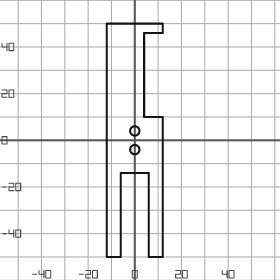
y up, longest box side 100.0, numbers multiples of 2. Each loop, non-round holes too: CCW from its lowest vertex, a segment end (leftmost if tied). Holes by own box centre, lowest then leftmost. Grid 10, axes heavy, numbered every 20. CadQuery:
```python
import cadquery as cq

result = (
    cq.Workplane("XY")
    .moveTo(-12.0, -50.0)
    .lineTo(-6.0, -50.0)
    .lineTo(-6.0, -14.0)
    .lineTo(6.0, -14.0)
    .lineTo(6.0, -50.0)
    .lineTo(12.0, -50.0)
    .lineTo(12.0, 10.0)
    .lineTo(4.0, 10.0)
    .lineTo(4.0, 46.0)
    .lineTo(12.0, 46.0)
    .lineTo(12.0, 50.0)
    .lineTo(-12.0, 50.0)
    .close()
    .moveTo(0.0, -4.0)
    .circle(2.0)
    .moveTo(0.0, 4.0)
    .circle(2.0)
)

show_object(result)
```